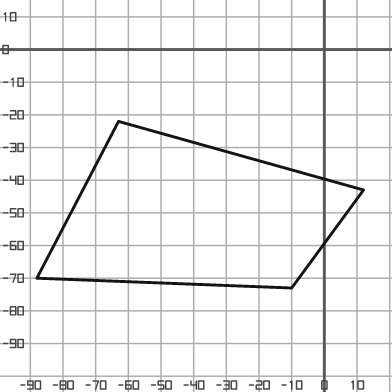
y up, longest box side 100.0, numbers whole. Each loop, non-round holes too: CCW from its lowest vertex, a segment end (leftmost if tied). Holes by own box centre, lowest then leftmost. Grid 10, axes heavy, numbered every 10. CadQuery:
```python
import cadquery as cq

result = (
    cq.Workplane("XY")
    .moveTo(-10.0, -73.0)
    .lineTo(12.0, -43.0)
    .lineTo(-63.0, -22.0)
    .lineTo(-88.0, -70.0)
    .close()
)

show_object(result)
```